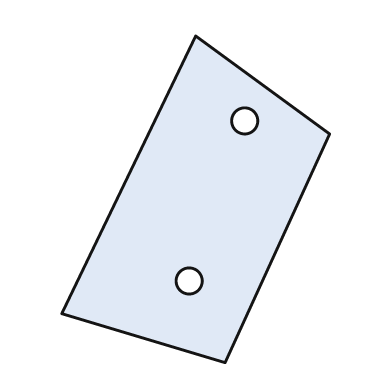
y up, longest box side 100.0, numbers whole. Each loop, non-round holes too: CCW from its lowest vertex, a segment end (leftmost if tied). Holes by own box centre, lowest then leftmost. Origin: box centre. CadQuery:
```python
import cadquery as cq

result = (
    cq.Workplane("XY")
    .moveTo(9.0, -50.0)
    .lineTo(41.0, 20.0)
    .lineTo(0.0, 50.0)
    .lineTo(-41.0, -35.0)
    .close()
    .moveTo(-2.0, -25.0)
    .circle(4.0)
    .moveTo(15.0, 24.0)
    .circle(4.0)
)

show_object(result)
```